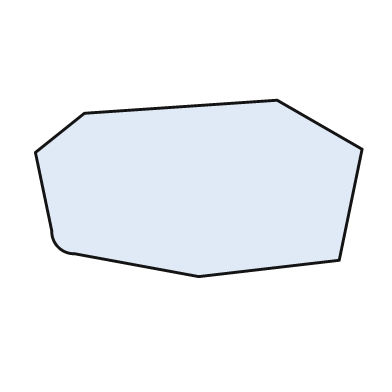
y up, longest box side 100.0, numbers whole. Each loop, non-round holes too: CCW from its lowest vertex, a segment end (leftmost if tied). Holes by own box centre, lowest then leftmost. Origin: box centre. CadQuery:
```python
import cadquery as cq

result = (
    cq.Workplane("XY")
    .moveTo(0.0, -27.0)
    .lineTo(43.0, -22.0)
    .lineTo(50.0, 12.0)
    .lineTo(24.0, 27.0)
    .lineTo(-35.0, 23.0)
    .lineTo(-50.0, 11.0)
    .lineTo(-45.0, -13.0)
    .threePointArc((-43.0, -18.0), (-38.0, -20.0))
    .close()
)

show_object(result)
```